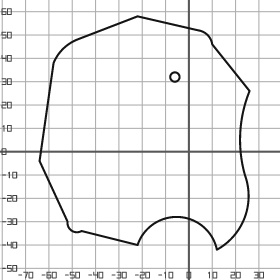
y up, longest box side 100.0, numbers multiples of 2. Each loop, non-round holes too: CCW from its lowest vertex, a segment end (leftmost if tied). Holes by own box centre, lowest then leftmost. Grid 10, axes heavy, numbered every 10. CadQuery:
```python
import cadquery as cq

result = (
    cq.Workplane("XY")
    .moveTo(12.0, -42.0)
    .threePointArc((24.0, -28.0), (24.0, -10.0))
    .threePointArc((22.0, 8.0), (26.0, 26.0))
    .lineTo(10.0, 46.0)
    .threePointArc((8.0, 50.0), (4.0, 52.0))
    .lineTo(-22.0, 58.0)
    .lineTo(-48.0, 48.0)
    .threePointArc((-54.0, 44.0), (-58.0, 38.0))
    .lineTo(-64.0, -4.0)
    .lineTo(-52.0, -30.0)
    .threePointArc((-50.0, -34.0), (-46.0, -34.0))
    .lineTo(-22.0, -40.0)
    .threePointArc((-4.0, -28.0), (12.0, -42.0))
    .close()
    .moveTo(-6.0, 32.0)
    .circle(2.0)
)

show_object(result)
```